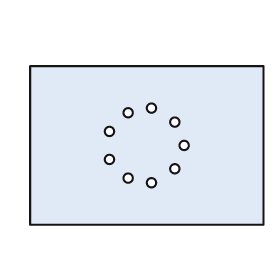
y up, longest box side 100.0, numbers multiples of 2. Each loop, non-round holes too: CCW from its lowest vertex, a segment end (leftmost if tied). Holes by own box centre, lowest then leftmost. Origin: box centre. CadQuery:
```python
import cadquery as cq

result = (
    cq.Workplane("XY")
    .moveTo(-50.0, -34.0)
    .lineTo(50.0, -34.0)
    .lineTo(50.0, 34.0)
    .lineTo(-50.0, 34.0)
    .close()
    .moveTo(2.0, -16.0)
    .circle(2.0)
    .moveTo(-8.0, -14.0)
    .circle(2.0)
    .moveTo(12.0, -10.0)
    .circle(2.0)
    .moveTo(-16.0, -6.0)
    .circle(2.0)
    .moveTo(16.0, 0.0)
    .circle(2.0)
    .moveTo(-16.0, 6.0)
    .circle(2.0)
    .moveTo(12.0, 10.0)
    .circle(2.0)
    .moveTo(-8.0, 14.0)
    .circle(2.0)
    .moveTo(2.0, 16.0)
    .circle(2.0)
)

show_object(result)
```